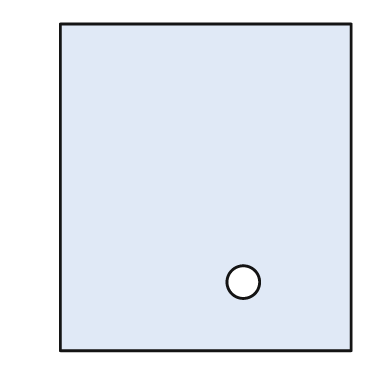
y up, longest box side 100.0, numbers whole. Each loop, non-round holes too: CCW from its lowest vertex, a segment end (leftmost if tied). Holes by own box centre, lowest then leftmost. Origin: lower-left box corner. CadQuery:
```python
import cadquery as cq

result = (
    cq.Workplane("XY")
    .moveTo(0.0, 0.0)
    .lineTo(89.0, 0.0)
    .lineTo(89.0, 100.0)
    .lineTo(0.0, 100.0)
    .close()
    .moveTo(56.0, 21.0)
    .circle(5.0)
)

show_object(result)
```